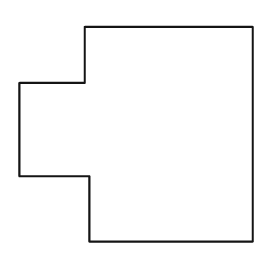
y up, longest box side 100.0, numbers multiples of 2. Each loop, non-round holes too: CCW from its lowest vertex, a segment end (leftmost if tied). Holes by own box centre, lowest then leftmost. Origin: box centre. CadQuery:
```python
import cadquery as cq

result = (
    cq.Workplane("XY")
    .moveTo(-20.0, -46.0)
    .lineTo(50.0, -46.0)
    .lineTo(50.0, 46.0)
    .lineTo(-22.0, 46.0)
    .lineTo(-22.0, 22.0)
    .lineTo(-50.0, 22.0)
    .lineTo(-50.0, -18.0)
    .lineTo(-20.0, -18.0)
    .close()
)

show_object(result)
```